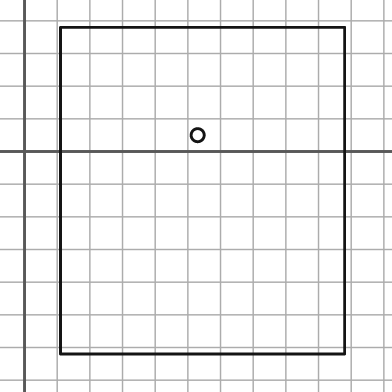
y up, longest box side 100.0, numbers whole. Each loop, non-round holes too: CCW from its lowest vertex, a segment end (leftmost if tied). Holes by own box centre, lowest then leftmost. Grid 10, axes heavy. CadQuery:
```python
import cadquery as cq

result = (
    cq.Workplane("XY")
    .moveTo(11.0, -62.0)
    .lineTo(98.0, -62.0)
    .lineTo(98.0, 38.0)
    .lineTo(11.0, 38.0)
    .close()
    .moveTo(53.0, 5.0)
    .circle(2.0)
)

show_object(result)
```